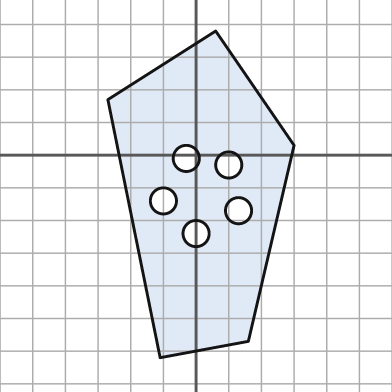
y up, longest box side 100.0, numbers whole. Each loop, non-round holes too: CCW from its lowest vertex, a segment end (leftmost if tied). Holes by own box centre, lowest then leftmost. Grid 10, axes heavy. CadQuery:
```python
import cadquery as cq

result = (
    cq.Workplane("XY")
    .moveTo(-11.0, -62.0)
    .lineTo(16.0, -57.0)
    .lineTo(30.0, 3.0)
    .lineTo(6.0, 38.0)
    .lineTo(-27.0, 17.0)
    .close()
    .moveTo(0.0, -24.0)
    .circle(4.0)
    .moveTo(13.0, -17.0)
    .circle(4.0)
    .moveTo(-10.0, -14.0)
    .circle(4.0)
    .moveTo(10.0, -3.0)
    .circle(4.0)
    .moveTo(-3.0, -1.0)
    .circle(4.0)
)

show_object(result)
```